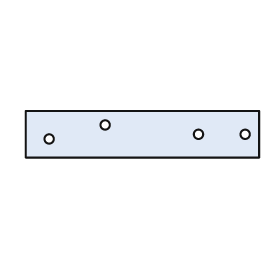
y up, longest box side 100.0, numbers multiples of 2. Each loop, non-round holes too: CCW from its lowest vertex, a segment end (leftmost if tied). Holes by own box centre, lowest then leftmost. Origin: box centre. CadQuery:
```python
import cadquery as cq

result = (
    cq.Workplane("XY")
    .moveTo(-50.0, -10.0)
    .lineTo(50.0, -10.0)
    .lineTo(50.0, 10.0)
    .lineTo(-50.0, 10.0)
    .close()
    .moveTo(-40.0, -2.0)
    .circle(2.0)
    .moveTo(24.0, 0.0)
    .circle(2.0)
    .moveTo(44.0, 0.0)
    .circle(2.0)
    .moveTo(-16.0, 4.0)
    .circle(2.0)
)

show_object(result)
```